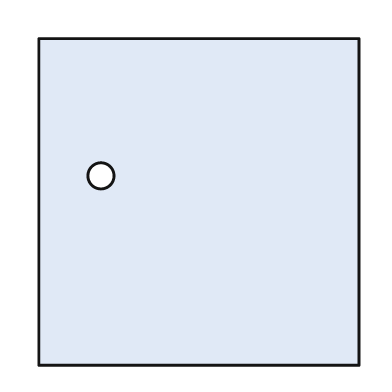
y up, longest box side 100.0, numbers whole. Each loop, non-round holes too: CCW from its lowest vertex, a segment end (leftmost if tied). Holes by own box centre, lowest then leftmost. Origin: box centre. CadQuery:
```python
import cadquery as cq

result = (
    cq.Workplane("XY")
    .moveTo(-49.0, -50.0)
    .lineTo(49.0, -50.0)
    .lineTo(49.0, 50.0)
    .lineTo(-49.0, 50.0)
    .close()
    .moveTo(-30.0, 8.0)
    .circle(4.0)
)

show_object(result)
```